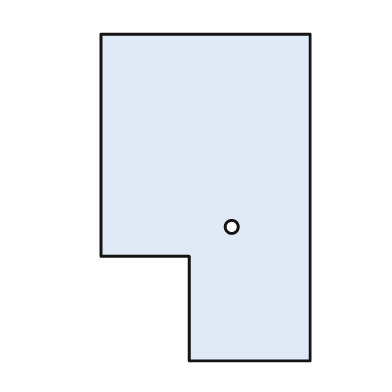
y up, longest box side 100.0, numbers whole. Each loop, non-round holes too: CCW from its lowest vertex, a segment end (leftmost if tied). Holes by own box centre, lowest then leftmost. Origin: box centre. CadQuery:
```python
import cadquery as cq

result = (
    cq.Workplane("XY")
    .moveTo(-5.0, -50.0)
    .lineTo(32.0, -50.0)
    .lineTo(32.0, 50.0)
    .lineTo(-32.0, 50.0)
    .lineTo(-32.0, -18.0)
    .lineTo(-5.0, -18.0)
    .close()
    .moveTo(8.0, -9.0)
    .circle(2.0)
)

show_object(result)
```